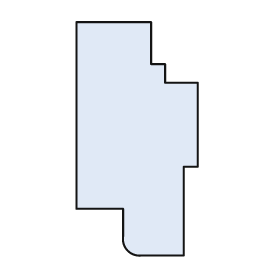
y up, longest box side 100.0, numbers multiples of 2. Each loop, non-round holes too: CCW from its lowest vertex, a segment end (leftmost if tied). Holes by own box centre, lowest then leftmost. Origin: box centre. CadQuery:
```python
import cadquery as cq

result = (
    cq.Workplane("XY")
    .moveTo(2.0, -50.0)
    .lineTo(20.0, -50.0)
    .lineTo(20.0, -12.0)
    .lineTo(26.0, -12.0)
    .lineTo(26.0, 24.0)
    .lineTo(12.0, 24.0)
    .lineTo(12.0, 32.0)
    .lineTo(6.0, 32.0)
    .lineTo(6.0, 50.0)
    .lineTo(-26.0, 50.0)
    .lineTo(-26.0, -30.0)
    .lineTo(-6.0, -30.0)
    .lineTo(-6.0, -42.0)
    .threePointArc((-4.0, -48.0), (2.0, -50.0))
    .close()
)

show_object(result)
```